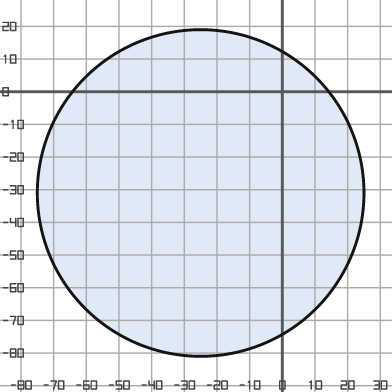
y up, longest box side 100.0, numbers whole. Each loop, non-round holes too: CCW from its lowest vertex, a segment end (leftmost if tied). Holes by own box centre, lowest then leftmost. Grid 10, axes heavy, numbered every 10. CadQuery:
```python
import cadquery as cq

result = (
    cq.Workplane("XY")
    .moveTo(-25.0, -31.0)
    .circle(50.0)
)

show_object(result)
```